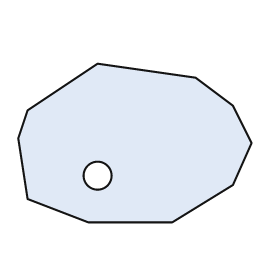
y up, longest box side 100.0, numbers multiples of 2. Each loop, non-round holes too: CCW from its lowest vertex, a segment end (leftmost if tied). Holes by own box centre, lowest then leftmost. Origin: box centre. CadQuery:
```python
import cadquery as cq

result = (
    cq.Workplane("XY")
    .moveTo(-20.0, -34.0)
    .lineTo(16.0, -34.0)
    .lineTo(42.0, -18.0)
    .lineTo(50.0, 0.0)
    .lineTo(42.0, 16.0)
    .lineTo(26.0, 28.0)
    .lineTo(-16.0, 34.0)
    .lineTo(-46.0, 14.0)
    .lineTo(-50.0, 2.0)
    .lineTo(-46.0, -24.0)
    .close()
    .moveTo(-16.0, -14.0)
    .circle(6.0)
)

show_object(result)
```